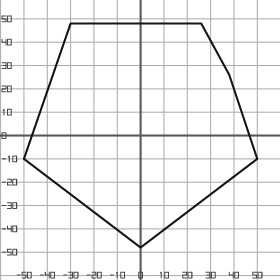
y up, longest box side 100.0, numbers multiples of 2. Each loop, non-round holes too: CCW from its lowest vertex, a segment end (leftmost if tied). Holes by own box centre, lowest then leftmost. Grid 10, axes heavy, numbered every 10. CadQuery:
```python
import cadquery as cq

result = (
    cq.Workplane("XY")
    .moveTo(0.0, -48.0)
    .lineTo(50.0, -10.0)
    .lineTo(38.0, 26.0)
    .lineTo(26.0, 48.0)
    .lineTo(-30.0, 48.0)
    .lineTo(-50.0, -10.0)
    .close()
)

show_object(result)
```